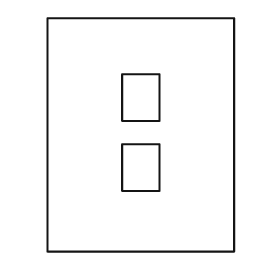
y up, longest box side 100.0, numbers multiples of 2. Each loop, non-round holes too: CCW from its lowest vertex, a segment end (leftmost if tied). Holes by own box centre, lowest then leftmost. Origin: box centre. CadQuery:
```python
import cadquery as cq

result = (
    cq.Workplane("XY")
    .moveTo(-40.0, -50.0)
    .lineTo(40.0, -50.0)
    .lineTo(40.0, 50.0)
    .lineTo(-40.0, 50.0)
    .close()
    .moveTo(-8.0, -24.0)
    .lineTo(8.0, -24.0)
    .lineTo(8.0, -4.0)
    .lineTo(-8.0, -4.0)
    .close()
    .moveTo(-8.0, 6.0)
    .lineTo(8.0, 6.0)
    .lineTo(8.0, 26.0)
    .lineTo(-8.0, 26.0)
    .close()
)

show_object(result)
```